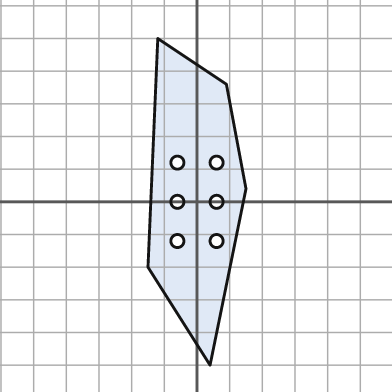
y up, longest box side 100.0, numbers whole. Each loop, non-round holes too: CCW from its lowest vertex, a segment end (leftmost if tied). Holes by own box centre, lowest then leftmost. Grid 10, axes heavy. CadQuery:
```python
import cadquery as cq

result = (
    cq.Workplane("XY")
    .moveTo(4.0, -50.0)
    .lineTo(15.0, 4.0)
    .lineTo(9.0, 36.0)
    .lineTo(-12.0, 50.0)
    .lineTo(-15.0, -20.0)
    .close()
    .moveTo(-6.0, -12.0)
    .circle(2.0)
    .moveTo(6.0, -12.0)
    .circle(2.0)
    .moveTo(-6.0, 0.0)
    .circle(2.0)
    .moveTo(6.0, 0.0)
    .circle(2.0)
    .moveTo(-6.0, 12.0)
    .circle(2.0)
    .moveTo(6.0, 12.0)
    .circle(2.0)
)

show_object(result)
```